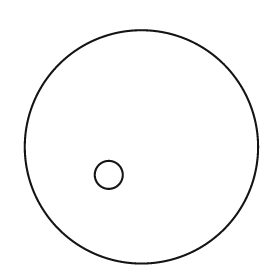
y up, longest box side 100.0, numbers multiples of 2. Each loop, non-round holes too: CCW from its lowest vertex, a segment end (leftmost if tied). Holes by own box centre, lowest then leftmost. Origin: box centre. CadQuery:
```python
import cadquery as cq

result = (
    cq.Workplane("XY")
    .moveTo(0.0, 0.0)
    .circle(50.0)
    .moveTo(-14.0, -12.0)
    .circle(6.0)
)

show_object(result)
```